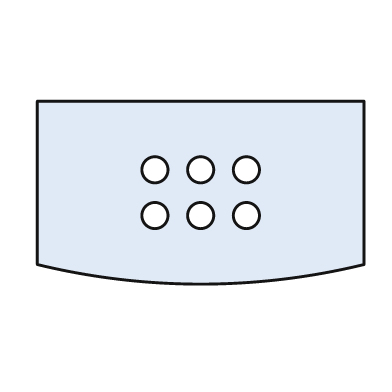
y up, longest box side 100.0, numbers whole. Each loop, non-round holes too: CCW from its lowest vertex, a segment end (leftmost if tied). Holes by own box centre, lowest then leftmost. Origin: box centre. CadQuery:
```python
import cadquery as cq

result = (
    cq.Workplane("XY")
    .moveTo(-50.0, -22.0)
    .threePointArc((0.0, -28.0), (50.0, -22.0))
    .lineTo(50.0, 28.0)
    .lineTo(-50.0, 28.0)
    .close()
    .moveTo(-14.0, -7.0)
    .circle(4.0)
    .moveTo(0.0, -7.0)
    .circle(4.0)
    .moveTo(14.0, -7.0)
    .circle(4.0)
    .moveTo(-14.0, 7.0)
    .circle(4.0)
    .moveTo(0.0, 7.0)
    .circle(4.0)
    .moveTo(14.0, 7.0)
    .circle(4.0)
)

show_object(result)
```